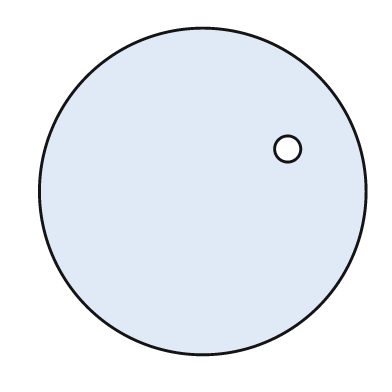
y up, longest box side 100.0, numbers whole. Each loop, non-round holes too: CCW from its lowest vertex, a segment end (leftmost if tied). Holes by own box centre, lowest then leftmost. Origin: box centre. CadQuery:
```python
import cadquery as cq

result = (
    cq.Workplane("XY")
    .moveTo(0.0, 0.0)
    .circle(50.0)
    .moveTo(26.0, 13.0)
    .circle(4.0)
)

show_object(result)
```